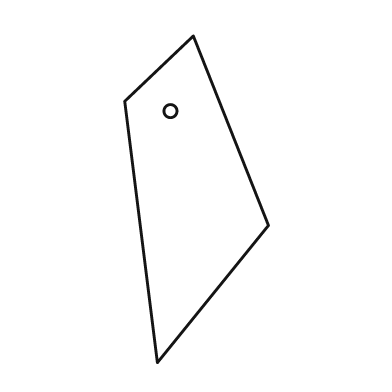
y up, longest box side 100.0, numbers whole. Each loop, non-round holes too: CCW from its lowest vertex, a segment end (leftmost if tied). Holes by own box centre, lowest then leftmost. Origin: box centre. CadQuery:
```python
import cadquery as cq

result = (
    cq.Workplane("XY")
    .moveTo(-12.0, -50.0)
    .lineTo(22.0, -8.0)
    .lineTo(-1.0, 50.0)
    .lineTo(-22.0, 30.0)
    .close()
    .moveTo(-8.0, 27.0)
    .circle(2.0)
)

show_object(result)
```